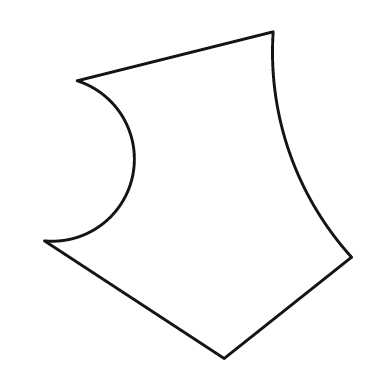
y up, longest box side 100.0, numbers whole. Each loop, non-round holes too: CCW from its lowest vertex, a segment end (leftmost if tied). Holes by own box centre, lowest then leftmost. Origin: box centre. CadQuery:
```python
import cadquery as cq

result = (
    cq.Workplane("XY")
    .moveTo(8.0, -50.0)
    .lineTo(47.0, -19.0)
    .threePointArc((28.0, 13.0), (23.0, 50.0))
    .lineTo(-37.0, 35.0)
    .threePointArc((-20.0, 6.0), (-47.0, -14.0))
    .close()
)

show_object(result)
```